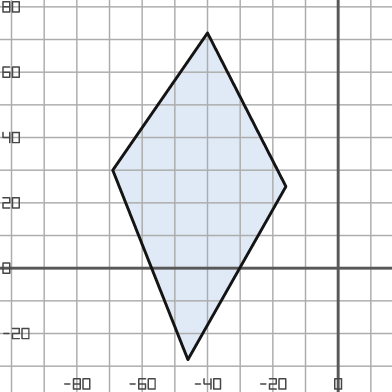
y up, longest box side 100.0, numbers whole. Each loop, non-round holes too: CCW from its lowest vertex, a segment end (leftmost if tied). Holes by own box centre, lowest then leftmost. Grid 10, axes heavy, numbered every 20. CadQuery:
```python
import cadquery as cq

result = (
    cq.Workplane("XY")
    .moveTo(-46.0, -28.0)
    .lineTo(-16.0, 25.0)
    .lineTo(-40.0, 72.0)
    .lineTo(-69.0, 30.0)
    .close()
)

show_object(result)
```